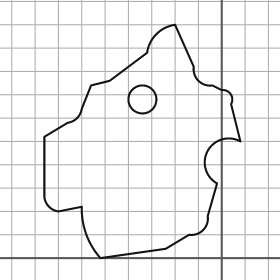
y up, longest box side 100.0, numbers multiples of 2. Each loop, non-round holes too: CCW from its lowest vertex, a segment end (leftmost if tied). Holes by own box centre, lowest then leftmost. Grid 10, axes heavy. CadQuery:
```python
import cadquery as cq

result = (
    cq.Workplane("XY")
    .moveTo(-52.0, 0.0)
    .lineTo(-24.0, 4.0)
    .lineTo(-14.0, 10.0)
    .threePointArc((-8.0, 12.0), (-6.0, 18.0))
    .lineTo(-2.0, 32.0)
    .threePointArc((-6.0, 46.0), (8.0, 50.0))
    .lineTo(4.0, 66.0)
    .threePointArc((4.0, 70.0), (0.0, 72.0))
    .lineTo(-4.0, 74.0)
    .threePointArc((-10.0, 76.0), (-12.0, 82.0))
    .lineTo(-20.0, 100.0)
    .threePointArc((-28.0, 96.0), (-32.0, 88.0))
    .lineTo(-48.0, 76.0)
    .lineTo(-56.0, 74.0)
    .lineTo(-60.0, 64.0)
    .threePointArc((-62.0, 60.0), (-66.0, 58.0))
    .lineTo(-76.0, 52.0)
    .lineTo(-76.0, 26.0)
    .threePointArc((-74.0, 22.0), (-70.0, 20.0))
    .lineTo(-60.0, 22.0)
    .threePointArc((-58.0, 10.0), (-52.0, 0.0))
    .close()
    .moveTo(-34.0, 68.0)
    .circle(6.0)
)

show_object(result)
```